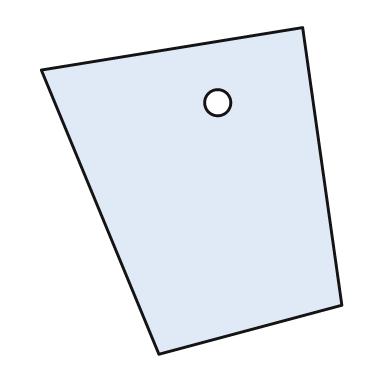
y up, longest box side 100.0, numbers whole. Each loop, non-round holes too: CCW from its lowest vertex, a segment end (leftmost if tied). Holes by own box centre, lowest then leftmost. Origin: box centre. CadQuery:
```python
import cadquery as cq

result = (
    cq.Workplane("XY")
    .moveTo(-10.0, -50.0)
    .lineTo(46.0, -35.0)
    .lineTo(34.0, 50.0)
    .lineTo(-46.0, 37.0)
    .close()
    .moveTo(8.0, 27.0)
    .circle(4.0)
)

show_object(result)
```